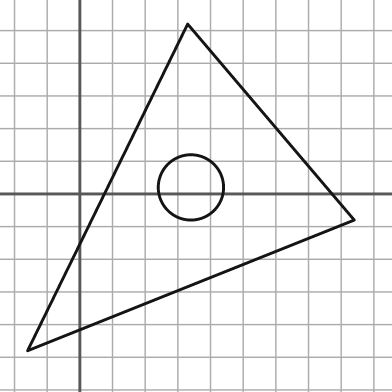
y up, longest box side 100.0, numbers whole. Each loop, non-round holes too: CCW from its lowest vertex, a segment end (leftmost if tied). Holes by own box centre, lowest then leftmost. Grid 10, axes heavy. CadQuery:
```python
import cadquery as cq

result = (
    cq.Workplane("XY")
    .moveTo(-16.0, -48.0)
    .lineTo(84.0, -8.0)
    .lineTo(33.0, 52.0)
    .close()
    .moveTo(34.0, 2.0)
    .circle(10.0)
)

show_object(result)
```